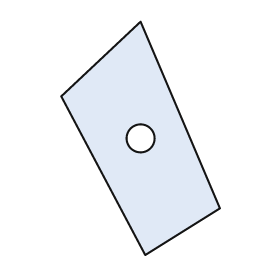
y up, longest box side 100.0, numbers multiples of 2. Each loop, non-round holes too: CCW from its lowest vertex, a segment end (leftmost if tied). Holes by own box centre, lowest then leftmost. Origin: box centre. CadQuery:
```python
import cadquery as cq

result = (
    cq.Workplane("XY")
    .moveTo(2.0, -50.0)
    .lineTo(34.0, -30.0)
    .lineTo(0.0, 50.0)
    .lineTo(-34.0, 18.0)
    .close()
    .moveTo(0.0, 0.0)
    .circle(6.0)
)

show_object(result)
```